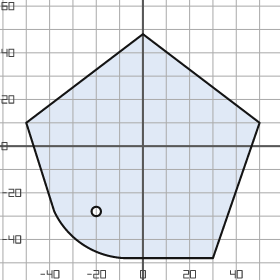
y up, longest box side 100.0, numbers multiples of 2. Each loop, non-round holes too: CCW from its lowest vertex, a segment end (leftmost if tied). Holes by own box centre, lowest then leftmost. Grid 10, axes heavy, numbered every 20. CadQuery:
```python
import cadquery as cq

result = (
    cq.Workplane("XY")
    .moveTo(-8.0, -48.0)
    .lineTo(30.0, -48.0)
    .lineTo(50.0, 10.0)
    .lineTo(0.0, 48.0)
    .lineTo(-50.0, 10.0)
    .lineTo(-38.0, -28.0)
    .threePointArc((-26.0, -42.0), (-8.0, -48.0))
    .close()
    .moveTo(-20.0, -28.0)
    .circle(2.0)
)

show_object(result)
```